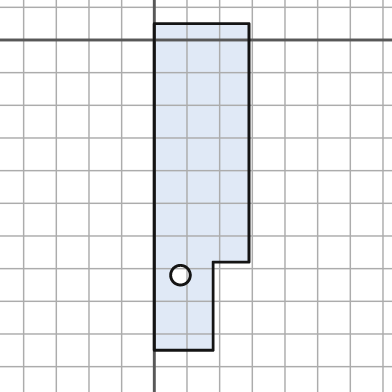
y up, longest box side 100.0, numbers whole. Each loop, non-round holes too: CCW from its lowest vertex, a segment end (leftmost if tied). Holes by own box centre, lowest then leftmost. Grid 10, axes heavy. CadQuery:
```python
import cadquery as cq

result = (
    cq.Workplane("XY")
    .moveTo(0.0, -95.0)
    .lineTo(18.0, -95.0)
    .lineTo(18.0, -68.0)
    .lineTo(29.0, -68.0)
    .lineTo(29.0, 5.0)
    .lineTo(0.0, 5.0)
    .close()
    .moveTo(8.0, -72.0)
    .circle(3.0)
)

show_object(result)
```